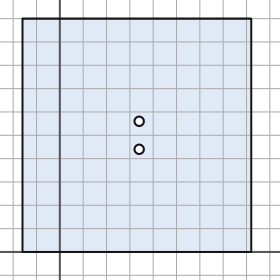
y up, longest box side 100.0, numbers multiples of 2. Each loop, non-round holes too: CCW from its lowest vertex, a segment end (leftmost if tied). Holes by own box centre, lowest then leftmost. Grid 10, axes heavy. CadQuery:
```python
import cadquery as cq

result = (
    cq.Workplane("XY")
    .moveTo(-16.0, 0.0)
    .lineTo(82.0, 0.0)
    .lineTo(82.0, 100.0)
    .lineTo(-16.0, 100.0)
    .close()
    .moveTo(34.0, 44.0)
    .circle(2.0)
    .moveTo(34.0, 56.0)
    .circle(2.0)
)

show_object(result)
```